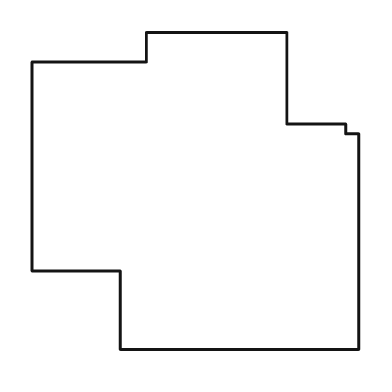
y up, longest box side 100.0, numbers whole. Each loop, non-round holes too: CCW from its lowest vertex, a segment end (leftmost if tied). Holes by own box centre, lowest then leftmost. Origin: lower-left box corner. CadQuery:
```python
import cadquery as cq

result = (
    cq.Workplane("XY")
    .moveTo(27.0, 0.0)
    .lineTo(100.0, 0.0)
    .lineTo(100.0, 66.0)
    .lineTo(96.0, 66.0)
    .lineTo(96.0, 69.0)
    .lineTo(78.0, 69.0)
    .lineTo(78.0, 97.0)
    .lineTo(35.0, 97.0)
    .lineTo(35.0, 88.0)
    .lineTo(0.0, 88.0)
    .lineTo(0.0, 24.0)
    .lineTo(27.0, 24.0)
    .close()
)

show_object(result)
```